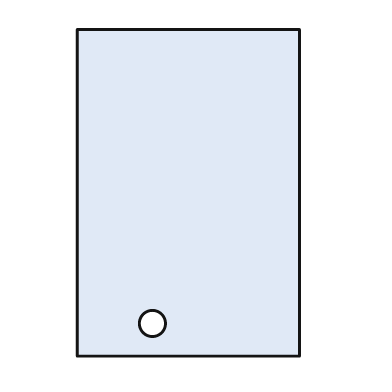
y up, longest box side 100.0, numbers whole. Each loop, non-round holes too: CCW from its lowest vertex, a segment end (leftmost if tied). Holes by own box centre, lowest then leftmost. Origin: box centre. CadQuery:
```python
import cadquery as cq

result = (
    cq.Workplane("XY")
    .moveTo(-34.0, -50.0)
    .lineTo(34.0, -50.0)
    .lineTo(34.0, 50.0)
    .lineTo(-34.0, 50.0)
    .close()
    .moveTo(-11.0, -40.0)
    .circle(4.0)
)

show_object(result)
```